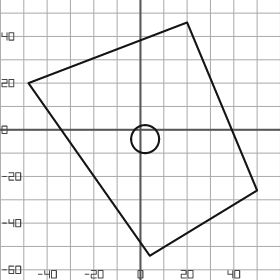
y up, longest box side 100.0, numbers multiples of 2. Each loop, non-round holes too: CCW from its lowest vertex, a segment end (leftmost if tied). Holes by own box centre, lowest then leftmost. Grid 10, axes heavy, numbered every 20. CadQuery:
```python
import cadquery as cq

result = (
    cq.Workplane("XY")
    .moveTo(4.0, -54.0)
    .lineTo(50.0, -26.0)
    .lineTo(20.0, 46.0)
    .lineTo(-48.0, 20.0)
    .close()
    .moveTo(2.0, -4.0)
    .circle(6.0)
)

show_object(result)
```